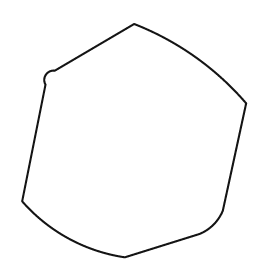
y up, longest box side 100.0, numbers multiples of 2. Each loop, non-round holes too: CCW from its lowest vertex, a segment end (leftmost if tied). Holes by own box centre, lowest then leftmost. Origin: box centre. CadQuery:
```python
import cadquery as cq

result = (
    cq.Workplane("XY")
    .moveTo(-4.0, -50.0)
    .lineTo(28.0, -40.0)
    .threePointArc((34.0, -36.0), (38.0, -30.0))
    .lineTo(48.0, 16.0)
    .threePointArc((26.0, 36.0), (0.0, 50.0))
    .lineTo(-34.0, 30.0)
    .threePointArc((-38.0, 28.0), (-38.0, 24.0))
    .lineTo(-48.0, -26.0)
    .threePointArc((-28.0, -42.0), (-4.0, -50.0))
    .close()
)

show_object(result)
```